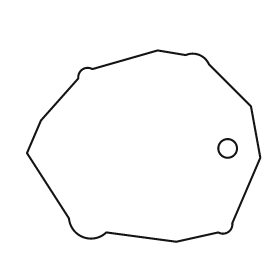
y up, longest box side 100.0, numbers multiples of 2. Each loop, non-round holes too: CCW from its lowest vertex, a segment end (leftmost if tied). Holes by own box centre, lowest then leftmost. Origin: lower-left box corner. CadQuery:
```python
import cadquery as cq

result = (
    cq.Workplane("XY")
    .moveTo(64.0, 0.0)
    .lineTo(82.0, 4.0)
    .threePointArc((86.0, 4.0), (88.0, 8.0))
    .lineTo(100.0, 36.0)
    .lineTo(96.0, 58.0)
    .lineTo(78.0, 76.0)
    .threePointArc((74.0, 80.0), (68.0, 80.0))
    .lineTo(56.0, 82.0)
    .lineTo(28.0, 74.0)
    .threePointArc((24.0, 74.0), (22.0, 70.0))
    .lineTo(6.0, 52.0)
    .lineTo(0.0, 38.0)
    .lineTo(18.0, 10.0)
    .threePointArc((24.0, 2.0), (34.0, 4.0))
    .close()
    .moveTo(86.0, 40.0)
    .circle(4.0)
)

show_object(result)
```